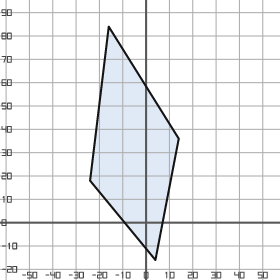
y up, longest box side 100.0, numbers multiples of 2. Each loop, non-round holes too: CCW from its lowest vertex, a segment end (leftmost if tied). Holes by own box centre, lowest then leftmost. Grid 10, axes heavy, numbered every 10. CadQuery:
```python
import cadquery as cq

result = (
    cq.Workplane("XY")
    .moveTo(4.0, -16.0)
    .lineTo(14.0, 36.0)
    .lineTo(-16.0, 84.0)
    .lineTo(-24.0, 18.0)
    .close()
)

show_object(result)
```